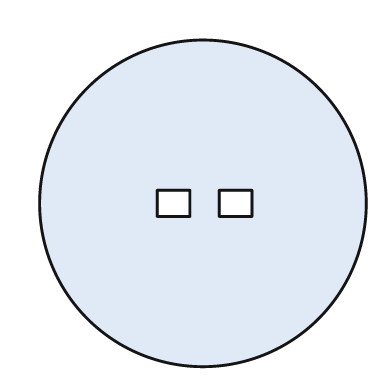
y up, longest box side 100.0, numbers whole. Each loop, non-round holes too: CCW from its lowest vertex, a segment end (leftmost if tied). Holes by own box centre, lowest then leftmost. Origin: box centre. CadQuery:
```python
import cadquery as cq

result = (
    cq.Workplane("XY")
    .moveTo(0.0, 0.0)
    .circle(50.0)
    .moveTo(-14.0, -4.0)
    .lineTo(-4.0, -4.0)
    .lineTo(-4.0, 4.0)
    .lineTo(-14.0, 4.0)
    .close()
    .moveTo(5.0, -4.0)
    .lineTo(15.0, -4.0)
    .lineTo(15.0, 4.0)
    .lineTo(5.0, 4.0)
    .close()
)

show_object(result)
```